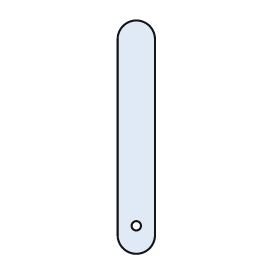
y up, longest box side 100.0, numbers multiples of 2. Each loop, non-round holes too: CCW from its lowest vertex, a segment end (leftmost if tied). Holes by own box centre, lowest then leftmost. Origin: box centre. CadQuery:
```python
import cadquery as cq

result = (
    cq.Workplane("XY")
    .moveTo(-8.0, -42.0)
    .threePointArc((0.0, -50.0), (8.0, -42.0))
    .lineTo(8.0, 42.0)
    .threePointArc((0.0, 50.0), (-8.0, 42.0))
    .close()
    .moveTo(0.0, -38.0)
    .circle(2.0)
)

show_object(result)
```